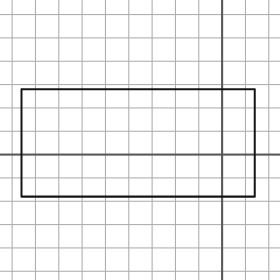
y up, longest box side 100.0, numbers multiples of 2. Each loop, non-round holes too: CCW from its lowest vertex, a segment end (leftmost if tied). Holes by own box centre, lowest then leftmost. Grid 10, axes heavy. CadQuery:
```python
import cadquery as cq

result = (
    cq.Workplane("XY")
    .moveTo(-86.0, -18.0)
    .lineTo(14.0, -18.0)
    .lineTo(14.0, 28.0)
    .lineTo(-86.0, 28.0)
    .close()
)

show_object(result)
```